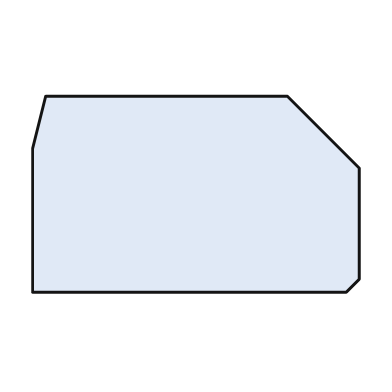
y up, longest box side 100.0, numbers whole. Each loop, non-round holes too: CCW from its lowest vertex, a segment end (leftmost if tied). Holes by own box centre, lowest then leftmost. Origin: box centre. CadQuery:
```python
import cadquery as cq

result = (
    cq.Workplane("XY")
    .moveTo(-50.0, -30.0)
    .lineTo(46.0, -30.0)
    .lineTo(50.0, -26.0)
    .lineTo(50.0, 8.0)
    .lineTo(28.0, 30.0)
    .lineTo(-46.0, 30.0)
    .lineTo(-50.0, 14.0)
    .close()
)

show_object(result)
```